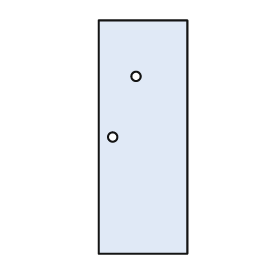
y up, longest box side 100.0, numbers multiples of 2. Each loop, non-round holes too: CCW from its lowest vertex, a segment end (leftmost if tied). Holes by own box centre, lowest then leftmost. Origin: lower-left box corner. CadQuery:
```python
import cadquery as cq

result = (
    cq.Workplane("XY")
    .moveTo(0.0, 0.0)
    .lineTo(38.0, 0.0)
    .lineTo(38.0, 100.0)
    .lineTo(0.0, 100.0)
    .close()
    .moveTo(6.0, 50.0)
    .circle(2.0)
    .moveTo(16.0, 76.0)
    .circle(2.0)
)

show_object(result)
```